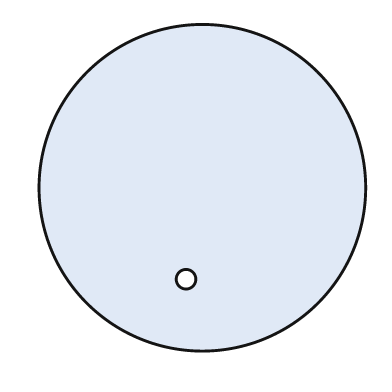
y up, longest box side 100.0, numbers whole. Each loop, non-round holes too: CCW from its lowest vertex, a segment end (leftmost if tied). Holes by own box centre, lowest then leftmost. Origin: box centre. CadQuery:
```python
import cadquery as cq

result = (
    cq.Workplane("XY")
    .moveTo(0.0, 0.0)
    .circle(50.0)
    .moveTo(-5.0, -28.0)
    .circle(3.0)
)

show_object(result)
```